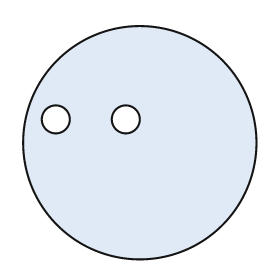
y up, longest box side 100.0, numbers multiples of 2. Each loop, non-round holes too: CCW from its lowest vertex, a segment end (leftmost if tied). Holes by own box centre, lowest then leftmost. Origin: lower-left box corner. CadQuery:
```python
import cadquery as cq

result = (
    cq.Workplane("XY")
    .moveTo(50.0, 50.0)
    .circle(50.0)
    .moveTo(14.0, 60.0)
    .circle(6.0)
    .moveTo(44.0, 60.0)
    .circle(6.0)
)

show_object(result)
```